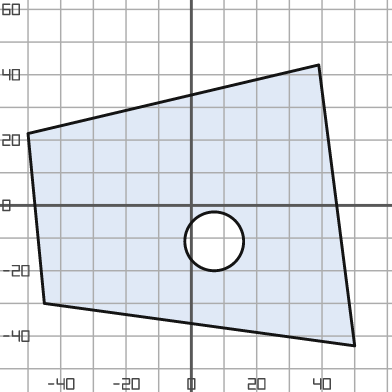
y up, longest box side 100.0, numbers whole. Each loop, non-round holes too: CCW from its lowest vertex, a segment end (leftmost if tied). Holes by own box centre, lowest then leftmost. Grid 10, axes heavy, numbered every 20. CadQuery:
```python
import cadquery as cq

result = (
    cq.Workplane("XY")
    .moveTo(50.0, -43.0)
    .lineTo(39.0, 43.0)
    .lineTo(-50.0, 22.0)
    .lineTo(-45.0, -30.0)
    .close()
    .moveTo(7.0, -11.0)
    .circle(9.0)
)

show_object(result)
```